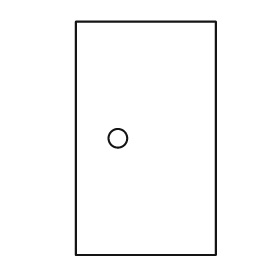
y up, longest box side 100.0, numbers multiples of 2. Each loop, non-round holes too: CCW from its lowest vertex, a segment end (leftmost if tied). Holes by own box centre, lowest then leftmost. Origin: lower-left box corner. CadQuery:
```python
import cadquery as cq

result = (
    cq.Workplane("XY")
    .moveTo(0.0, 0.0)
    .lineTo(60.0, 0.0)
    .lineTo(60.0, 100.0)
    .lineTo(0.0, 100.0)
    .close()
    .moveTo(18.0, 50.0)
    .circle(4.0)
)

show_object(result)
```